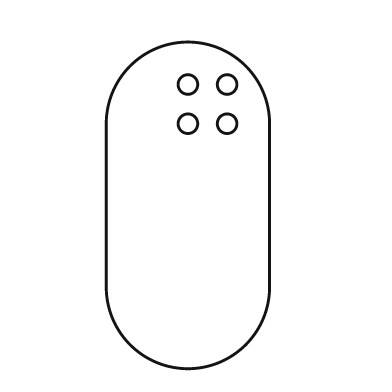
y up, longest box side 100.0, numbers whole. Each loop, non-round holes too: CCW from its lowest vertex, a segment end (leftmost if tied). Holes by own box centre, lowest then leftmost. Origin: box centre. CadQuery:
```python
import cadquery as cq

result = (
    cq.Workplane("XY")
    .moveTo(-25.0, -25.0)
    .threePointArc((0.0, -50.0), (25.0, -25.0))
    .lineTo(25.0, 25.0)
    .threePointArc((0.0, 50.0), (-25.0, 25.0))
    .close()
    .moveTo(0.0, 25.0)
    .circle(3.0)
    .moveTo(12.0, 25.0)
    .circle(3.0)
    .moveTo(0.0, 37.0)
    .circle(3.0)
    .moveTo(12.0, 37.0)
    .circle(3.0)
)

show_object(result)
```